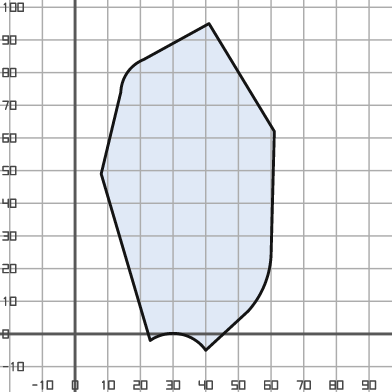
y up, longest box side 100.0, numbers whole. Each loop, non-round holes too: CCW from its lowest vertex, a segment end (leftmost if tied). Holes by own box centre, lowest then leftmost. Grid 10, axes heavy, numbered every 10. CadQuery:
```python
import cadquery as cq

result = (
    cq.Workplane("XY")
    .moveTo(40.0, -5.0)
    .lineTo(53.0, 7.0)
    .threePointArc((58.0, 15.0), (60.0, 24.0))
    .lineTo(61.0, 62.0)
    .lineTo(41.0, 95.0)
    .lineTo(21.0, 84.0)
    .threePointArc((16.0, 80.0), (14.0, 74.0))
    .lineTo(8.0, 49.0)
    .lineTo(23.0, -2.0)
    .threePointArc((32.0, 0.0), (40.0, -5.0))
    .close()
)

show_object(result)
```